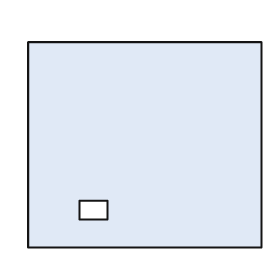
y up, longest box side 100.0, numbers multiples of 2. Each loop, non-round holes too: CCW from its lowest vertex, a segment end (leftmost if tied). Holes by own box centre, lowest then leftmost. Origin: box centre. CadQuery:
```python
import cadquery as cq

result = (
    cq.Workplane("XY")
    .moveTo(-50.0, -44.0)
    .lineTo(50.0, -44.0)
    .lineTo(50.0, 44.0)
    .lineTo(-50.0, 44.0)
    .close()
    .moveTo(-28.0, -32.0)
    .lineTo(-16.0, -32.0)
    .lineTo(-16.0, -24.0)
    .lineTo(-28.0, -24.0)
    .close()
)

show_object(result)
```